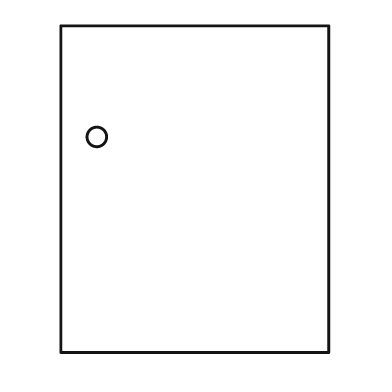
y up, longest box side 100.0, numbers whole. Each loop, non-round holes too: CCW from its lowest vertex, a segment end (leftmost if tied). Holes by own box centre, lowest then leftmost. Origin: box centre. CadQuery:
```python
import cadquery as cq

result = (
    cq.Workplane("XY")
    .moveTo(-41.0, -50.0)
    .lineTo(41.0, -50.0)
    .lineTo(41.0, 50.0)
    .lineTo(-41.0, 50.0)
    .close()
    .moveTo(-30.0, 16.0)
    .circle(3.0)
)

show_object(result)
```